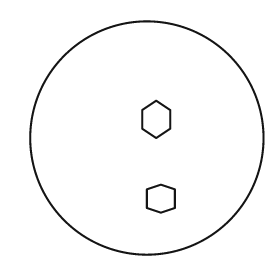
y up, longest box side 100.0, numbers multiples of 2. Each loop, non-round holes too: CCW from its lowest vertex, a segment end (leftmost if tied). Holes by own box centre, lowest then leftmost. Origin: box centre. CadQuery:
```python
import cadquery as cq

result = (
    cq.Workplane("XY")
    .moveTo(0.0, 0.0)
    .circle(50.0)
    .moveTo(6.0, -32.0)
    .lineTo(12.0, -30.0)
    .lineTo(12.0, -22.0)
    .lineTo(6.0, -20.0)
    .lineTo(0.0, -22.0)
    .lineTo(0.0, -30.0)
    .close()
    .moveTo(4.0, 0.0)
    .lineTo(10.0, 4.0)
    .lineTo(10.0, 12.0)
    .lineTo(4.0, 16.0)
    .lineTo(-2.0, 12.0)
    .lineTo(-2.0, 4.0)
    .close()
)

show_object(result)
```